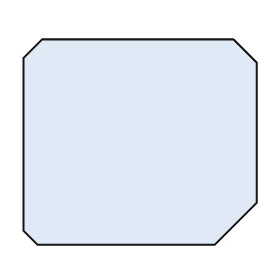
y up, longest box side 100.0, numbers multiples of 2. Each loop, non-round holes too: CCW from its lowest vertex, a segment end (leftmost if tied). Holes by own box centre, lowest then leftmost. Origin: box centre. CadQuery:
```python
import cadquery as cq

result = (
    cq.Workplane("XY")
    .moveTo(-44.0, -44.0)
    .lineTo(32.0, -44.0)
    .lineTo(50.0, -26.0)
    .lineTo(50.0, 34.0)
    .lineTo(40.0, 44.0)
    .lineTo(-42.0, 44.0)
    .lineTo(-50.0, 36.0)
    .lineTo(-50.0, -38.0)
    .close()
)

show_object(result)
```